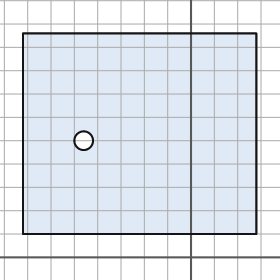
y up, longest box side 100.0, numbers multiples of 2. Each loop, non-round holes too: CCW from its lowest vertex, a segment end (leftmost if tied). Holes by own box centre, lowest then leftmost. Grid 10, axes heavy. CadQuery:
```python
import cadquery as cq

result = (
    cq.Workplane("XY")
    .moveTo(-72.0, 10.0)
    .lineTo(28.0, 10.0)
    .lineTo(28.0, 96.0)
    .lineTo(-72.0, 96.0)
    .close()
    .moveTo(-46.0, 50.0)
    .circle(4.0)
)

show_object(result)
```